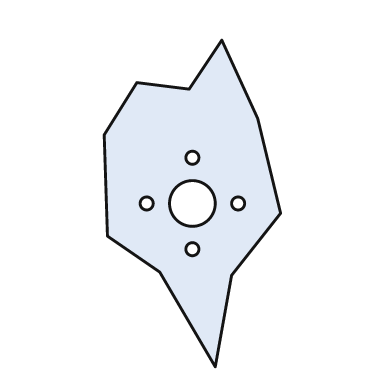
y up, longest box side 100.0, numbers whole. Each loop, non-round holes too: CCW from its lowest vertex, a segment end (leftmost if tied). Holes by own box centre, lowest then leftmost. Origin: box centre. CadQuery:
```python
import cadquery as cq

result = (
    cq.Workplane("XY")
    .moveTo(7.0, -50.0)
    .lineTo(12.0, -22.0)
    .lineTo(27.0, -3.0)
    .lineTo(20.0, 26.0)
    .lineTo(9.0, 50.0)
    .lineTo(-1.0, 35.0)
    .lineTo(-17.0, 37.0)
    .lineTo(-27.0, 21.0)
    .lineTo(-26.0, -10.0)
    .lineTo(-10.0, -21.0)
    .close()
    .moveTo(0.0, -14.0)
    .circle(2.0)
    .moveTo(-14.0, 0.0)
    .circle(2.0)
    .moveTo(0.0, 0.0)
    .circle(7.0)
    .moveTo(14.0, 0.0)
    .circle(2.0)
    .moveTo(0.0, 14.0)
    .circle(2.0)
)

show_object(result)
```